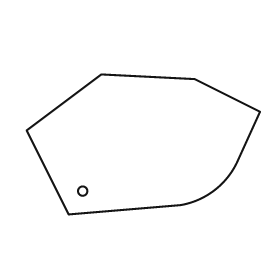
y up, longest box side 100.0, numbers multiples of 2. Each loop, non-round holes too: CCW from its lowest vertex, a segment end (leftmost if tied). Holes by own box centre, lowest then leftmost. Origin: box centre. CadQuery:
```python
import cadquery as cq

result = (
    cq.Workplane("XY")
    .moveTo(-32.0, -30.0)
    .lineTo(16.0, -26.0)
    .threePointArc((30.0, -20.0), (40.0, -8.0))
    .lineTo(50.0, 14.0)
    .lineTo(22.0, 28.0)
    .lineTo(-18.0, 30.0)
    .lineTo(-50.0, 6.0)
    .close()
    .moveTo(-26.0, -20.0)
    .circle(2.0)
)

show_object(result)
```